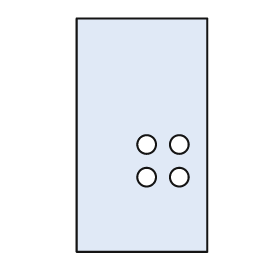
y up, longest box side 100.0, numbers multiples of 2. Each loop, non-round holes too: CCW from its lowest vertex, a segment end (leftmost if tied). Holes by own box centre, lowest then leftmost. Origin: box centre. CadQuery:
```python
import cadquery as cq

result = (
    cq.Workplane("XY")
    .moveTo(-28.0, -50.0)
    .lineTo(28.0, -50.0)
    .lineTo(28.0, 50.0)
    .lineTo(-28.0, 50.0)
    .close()
    .moveTo(2.0, -18.0)
    .circle(4.0)
    .moveTo(16.0, -18.0)
    .circle(4.0)
    .moveTo(2.0, -4.0)
    .circle(4.0)
    .moveTo(16.0, -4.0)
    .circle(4.0)
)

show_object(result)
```